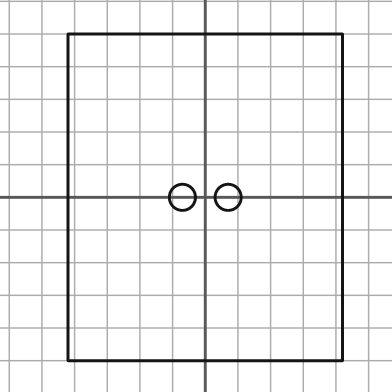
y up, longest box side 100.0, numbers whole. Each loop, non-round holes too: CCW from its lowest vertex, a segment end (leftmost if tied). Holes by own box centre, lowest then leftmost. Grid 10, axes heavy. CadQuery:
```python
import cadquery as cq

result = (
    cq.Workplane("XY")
    .moveTo(-42.0, -50.0)
    .lineTo(42.0, -50.0)
    .lineTo(42.0, 50.0)
    .lineTo(-42.0, 50.0)
    .close()
    .moveTo(-7.0, 0.0)
    .circle(4.0)
    .moveTo(7.0, 0.0)
    .circle(4.0)
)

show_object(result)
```